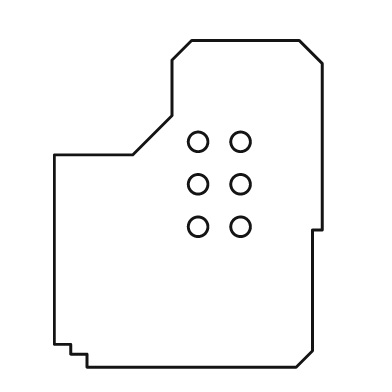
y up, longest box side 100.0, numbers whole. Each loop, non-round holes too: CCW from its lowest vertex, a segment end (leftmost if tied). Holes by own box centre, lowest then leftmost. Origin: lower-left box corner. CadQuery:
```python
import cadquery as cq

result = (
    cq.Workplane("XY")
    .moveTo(10.0, 0.0)
    .lineTo(74.0, 0.0)
    .lineTo(79.0, 5.0)
    .lineTo(79.0, 42.0)
    .lineTo(82.0, 42.0)
    .lineTo(82.0, 93.0)
    .lineTo(75.0, 100.0)
    .lineTo(42.0, 100.0)
    .lineTo(36.0, 94.0)
    .lineTo(36.0, 77.0)
    .lineTo(24.0, 65.0)
    .lineTo(0.0, 65.0)
    .lineTo(0.0, 7.0)
    .lineTo(5.0, 7.0)
    .lineTo(5.0, 4.0)
    .lineTo(10.0, 4.0)
    .close()
    .moveTo(44.0, 43.0)
    .circle(3.0)
    .moveTo(57.0, 43.0)
    .circle(3.0)
    .moveTo(44.0, 56.0)
    .circle(3.0)
    .moveTo(57.0, 56.0)
    .circle(3.0)
    .moveTo(44.0, 69.0)
    .circle(3.0)
    .moveTo(57.0, 69.0)
    .circle(3.0)
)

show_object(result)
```